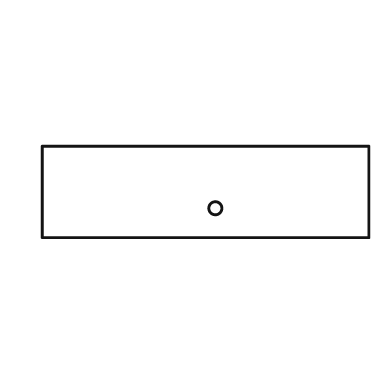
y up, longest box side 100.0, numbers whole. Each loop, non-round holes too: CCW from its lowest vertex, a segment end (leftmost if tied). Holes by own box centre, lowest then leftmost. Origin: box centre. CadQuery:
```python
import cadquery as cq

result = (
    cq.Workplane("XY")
    .moveTo(-50.0, -14.0)
    .lineTo(50.0, -14.0)
    .lineTo(50.0, 14.0)
    .lineTo(-50.0, 14.0)
    .close()
    .moveTo(3.0, -5.0)
    .circle(2.0)
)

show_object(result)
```